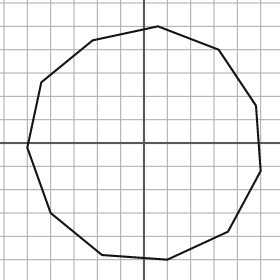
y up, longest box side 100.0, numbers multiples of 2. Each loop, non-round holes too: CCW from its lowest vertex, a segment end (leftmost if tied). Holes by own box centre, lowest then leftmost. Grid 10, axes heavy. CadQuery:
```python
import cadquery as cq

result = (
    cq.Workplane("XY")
    .moveTo(10.0, -50.0)
    .lineTo(36.0, -38.0)
    .lineTo(50.0, -12.0)
    .lineTo(48.0, 16.0)
    .lineTo(32.0, 40.0)
    .lineTo(6.0, 50.0)
    .lineTo(-22.0, 44.0)
    .lineTo(-44.0, 26.0)
    .lineTo(-50.0, -2.0)
    .lineTo(-40.0, -30.0)
    .lineTo(-18.0, -48.0)
    .close()
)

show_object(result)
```